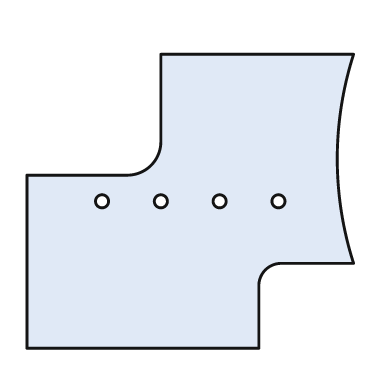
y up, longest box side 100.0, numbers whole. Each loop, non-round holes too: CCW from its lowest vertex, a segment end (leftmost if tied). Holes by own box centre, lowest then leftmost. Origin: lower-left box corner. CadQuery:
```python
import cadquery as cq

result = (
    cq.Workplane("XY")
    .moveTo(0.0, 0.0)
    .lineTo(71.0, 0.0)
    .lineTo(71.0, 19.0)
    .threePointArc((73.0, 24.0), (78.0, 26.0))
    .lineTo(100.0, 26.0)
    .threePointArc((95.0, 58.0), (100.0, 90.0))
    .lineTo(41.0, 90.0)
    .lineTo(41.0, 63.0)
    .threePointArc((38.0, 56.0), (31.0, 53.0))
    .lineTo(0.0, 53.0)
    .close()
    .moveTo(23.0, 45.0)
    .circle(2.0)
    .moveTo(41.0, 45.0)
    .circle(2.0)
    .moveTo(59.0, 45.0)
    .circle(2.0)
    .moveTo(77.0, 45.0)
    .circle(2.0)
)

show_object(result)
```